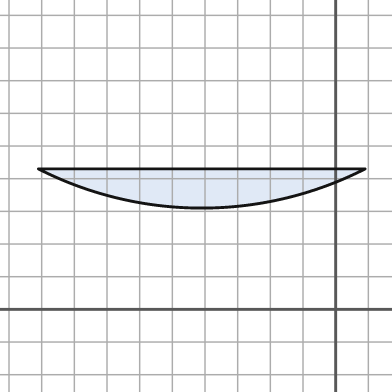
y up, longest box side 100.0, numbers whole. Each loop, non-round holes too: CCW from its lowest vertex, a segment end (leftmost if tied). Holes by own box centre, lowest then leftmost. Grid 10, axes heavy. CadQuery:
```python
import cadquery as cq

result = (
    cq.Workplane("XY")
    .moveTo(-91.0, 43.0)
    .threePointArc((-41.0, 31.0), (9.0, 43.0))
    .close()
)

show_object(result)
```